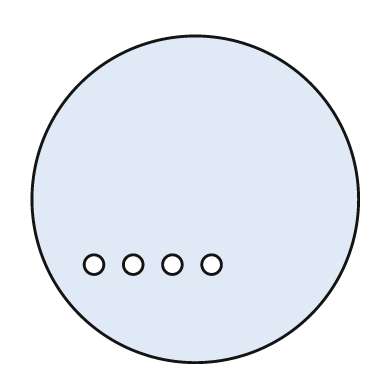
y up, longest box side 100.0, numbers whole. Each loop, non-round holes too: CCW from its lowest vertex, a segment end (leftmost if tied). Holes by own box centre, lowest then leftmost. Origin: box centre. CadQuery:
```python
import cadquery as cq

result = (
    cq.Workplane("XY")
    .moveTo(0.0, 0.0)
    .circle(50.0)
    .moveTo(-31.0, -20.0)
    .circle(3.0)
    .moveTo(-19.0, -20.0)
    .circle(3.0)
    .moveTo(-7.0, -20.0)
    .circle(3.0)
    .moveTo(5.0, -20.0)
    .circle(3.0)
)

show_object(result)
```